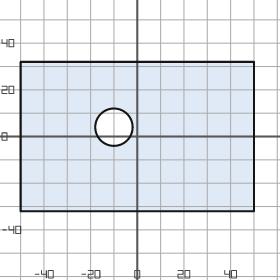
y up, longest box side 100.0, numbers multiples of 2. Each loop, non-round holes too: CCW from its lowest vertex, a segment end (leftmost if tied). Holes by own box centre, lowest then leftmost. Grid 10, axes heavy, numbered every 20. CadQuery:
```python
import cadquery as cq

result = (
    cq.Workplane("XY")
    .moveTo(-50.0, -32.0)
    .lineTo(50.0, -32.0)
    .lineTo(50.0, 32.0)
    .lineTo(-50.0, 32.0)
    .close()
    .moveTo(-10.0, 4.0)
    .circle(8.0)
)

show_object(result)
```